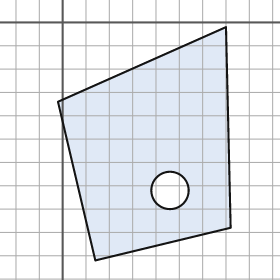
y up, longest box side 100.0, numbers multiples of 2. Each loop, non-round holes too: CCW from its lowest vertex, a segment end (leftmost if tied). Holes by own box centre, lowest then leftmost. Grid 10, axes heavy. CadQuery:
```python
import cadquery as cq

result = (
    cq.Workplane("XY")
    .moveTo(14.0, -102.0)
    .lineTo(72.0, -88.0)
    .lineTo(70.0, -2.0)
    .lineTo(-2.0, -34.0)
    .close()
    .moveTo(46.0, -72.0)
    .circle(8.0)
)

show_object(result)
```